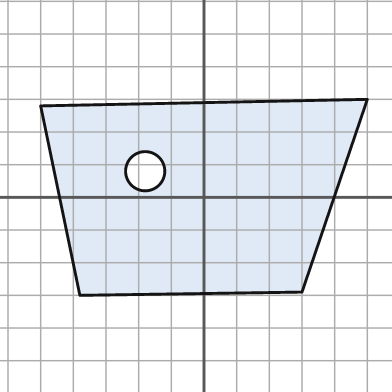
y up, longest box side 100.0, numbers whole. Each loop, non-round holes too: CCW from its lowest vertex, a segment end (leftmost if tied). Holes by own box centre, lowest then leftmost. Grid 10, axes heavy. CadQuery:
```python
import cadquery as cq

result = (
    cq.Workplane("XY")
    .moveTo(-38.0, -30.0)
    .lineTo(30.0, -29.0)
    .lineTo(50.0, 30.0)
    .lineTo(-50.0, 28.0)
    .close()
    .moveTo(-18.0, 8.0)
    .circle(6.0)
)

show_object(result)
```